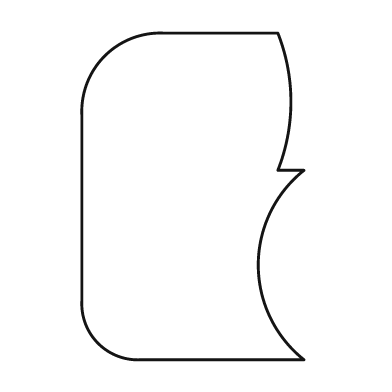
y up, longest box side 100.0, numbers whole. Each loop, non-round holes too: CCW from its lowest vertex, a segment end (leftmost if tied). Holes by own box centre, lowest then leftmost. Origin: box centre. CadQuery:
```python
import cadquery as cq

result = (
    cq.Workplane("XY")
    .moveTo(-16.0, -50.0)
    .lineTo(34.0, -50.0)
    .threePointArc((20.0, -21.0), (34.0, 8.0))
    .lineTo(26.0, 8.0)
    .threePointArc((30.0, 29.0), (26.0, 50.0))
    .lineTo(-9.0, 50.0)
    .threePointArc((-27.0, 43.0), (-34.0, 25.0))
    .lineTo(-34.0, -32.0)
    .threePointArc((-29.0, -45.0), (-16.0, -50.0))
    .close()
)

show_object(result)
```